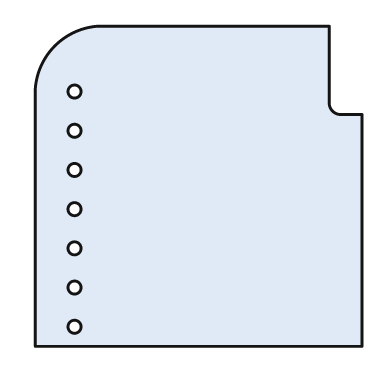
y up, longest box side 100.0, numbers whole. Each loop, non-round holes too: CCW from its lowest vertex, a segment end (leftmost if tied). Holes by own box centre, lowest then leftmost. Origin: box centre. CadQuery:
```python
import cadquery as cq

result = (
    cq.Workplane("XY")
    .moveTo(-50.0, -49.0)
    .lineTo(50.0, -49.0)
    .lineTo(50.0, 22.0)
    .lineTo(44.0, 22.0)
    .threePointArc((41.0, 23.0), (40.0, 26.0))
    .lineTo(40.0, 49.0)
    .lineTo(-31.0, 49.0)
    .threePointArc((-44.0, 43.0), (-50.0, 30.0))
    .close()
    .moveTo(-38.0, -43.0)
    .circle(2.0)
    .moveTo(-38.0, -31.0)
    .circle(2.0)
    .moveTo(-38.0, -19.0)
    .circle(2.0)
    .moveTo(-38.0, -7.0)
    .circle(2.0)
    .moveTo(-38.0, 5.0)
    .circle(2.0)
    .moveTo(-38.0, 17.0)
    .circle(2.0)
    .moveTo(-38.0, 29.0)
    .circle(2.0)
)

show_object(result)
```